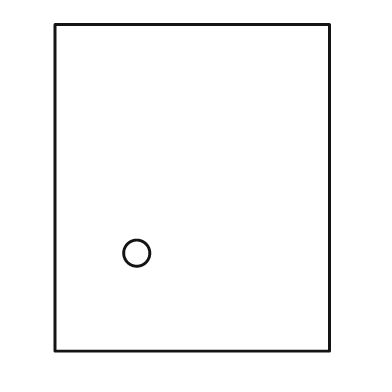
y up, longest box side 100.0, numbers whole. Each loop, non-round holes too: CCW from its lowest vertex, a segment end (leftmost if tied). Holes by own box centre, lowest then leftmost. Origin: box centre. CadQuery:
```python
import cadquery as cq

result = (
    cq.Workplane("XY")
    .moveTo(-42.0, -50.0)
    .lineTo(42.0, -50.0)
    .lineTo(42.0, 50.0)
    .lineTo(-42.0, 50.0)
    .close()
    .moveTo(-17.0, -20.0)
    .circle(4.0)
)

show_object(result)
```